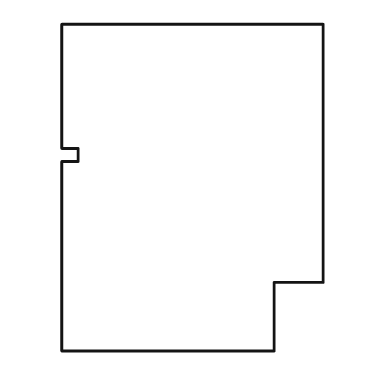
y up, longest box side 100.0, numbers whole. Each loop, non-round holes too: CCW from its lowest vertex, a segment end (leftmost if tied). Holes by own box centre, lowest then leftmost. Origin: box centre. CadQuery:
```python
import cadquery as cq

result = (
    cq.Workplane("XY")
    .moveTo(-40.0, -50.0)
    .lineTo(25.0, -50.0)
    .lineTo(25.0, -29.0)
    .lineTo(40.0, -29.0)
    .lineTo(40.0, 50.0)
    .lineTo(-40.0, 50.0)
    .lineTo(-40.0, 12.0)
    .lineTo(-35.0, 12.0)
    .lineTo(-35.0, 8.0)
    .lineTo(-40.0, 8.0)
    .close()
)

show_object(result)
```